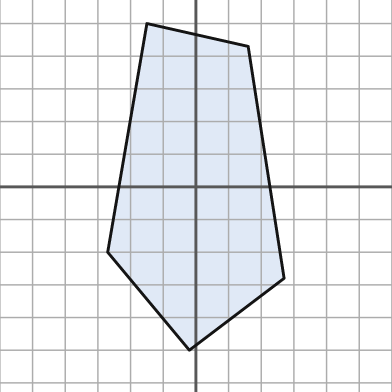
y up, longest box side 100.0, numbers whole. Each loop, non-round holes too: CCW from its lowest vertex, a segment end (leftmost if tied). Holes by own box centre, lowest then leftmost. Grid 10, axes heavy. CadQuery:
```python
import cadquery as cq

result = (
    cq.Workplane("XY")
    .moveTo(-2.0, -50.0)
    .lineTo(27.0, -28.0)
    .lineTo(16.0, 43.0)
    .lineTo(-15.0, 50.0)
    .lineTo(-27.0, -20.0)
    .close()
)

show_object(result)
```